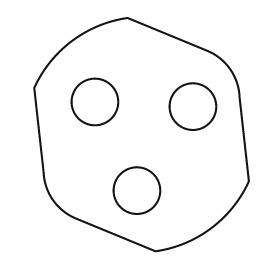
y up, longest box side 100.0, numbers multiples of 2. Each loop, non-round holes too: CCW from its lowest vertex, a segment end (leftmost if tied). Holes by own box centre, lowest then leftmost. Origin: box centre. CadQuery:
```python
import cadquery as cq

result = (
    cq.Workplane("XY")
    .moveTo(6.0, -50.0)
    .threePointArc((30.0, -40.0), (46.0, -20.0))
    .lineTo(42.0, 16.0)
    .threePointArc((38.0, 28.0), (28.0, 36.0))
    .lineTo(-6.0, 50.0)
    .threePointArc((-30.0, 40.0), (-46.0, 20.0))
    .lineTo(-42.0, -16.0)
    .threePointArc((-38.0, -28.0), (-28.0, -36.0))
    .close()
    .moveTo(-2.0, -24.0)
    .circle(10.0)
    .moveTo(22.0, 12.0)
    .circle(10.0)
    .moveTo(-20.0, 14.0)
    .circle(10.0)
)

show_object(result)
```